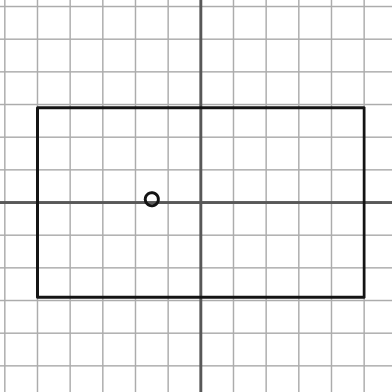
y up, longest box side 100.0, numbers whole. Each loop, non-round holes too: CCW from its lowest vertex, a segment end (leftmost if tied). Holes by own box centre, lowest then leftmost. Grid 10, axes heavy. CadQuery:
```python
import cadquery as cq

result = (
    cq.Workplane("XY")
    .moveTo(-50.0, -29.0)
    .lineTo(50.0, -29.0)
    .lineTo(50.0, 29.0)
    .lineTo(-50.0, 29.0)
    .close()
    .moveTo(-15.0, 1.0)
    .circle(2.0)
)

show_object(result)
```